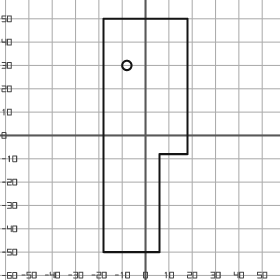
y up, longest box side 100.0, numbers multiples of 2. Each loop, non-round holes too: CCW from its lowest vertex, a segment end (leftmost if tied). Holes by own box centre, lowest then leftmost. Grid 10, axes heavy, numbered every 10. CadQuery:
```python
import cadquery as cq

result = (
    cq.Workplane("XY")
    .moveTo(-18.0, -50.0)
    .lineTo(6.0, -50.0)
    .lineTo(6.0, -8.0)
    .lineTo(18.0, -8.0)
    .lineTo(18.0, 50.0)
    .lineTo(-18.0, 50.0)
    .close()
    .moveTo(-8.0, 30.0)
    .circle(2.0)
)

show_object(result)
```